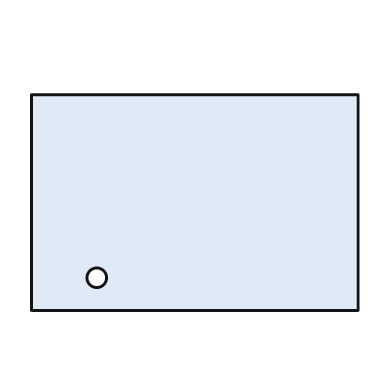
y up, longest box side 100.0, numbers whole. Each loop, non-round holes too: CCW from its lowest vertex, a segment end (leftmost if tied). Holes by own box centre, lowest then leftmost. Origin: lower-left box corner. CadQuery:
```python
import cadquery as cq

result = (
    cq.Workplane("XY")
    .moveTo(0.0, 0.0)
    .lineTo(100.0, 0.0)
    .lineTo(100.0, 66.0)
    .lineTo(0.0, 66.0)
    .close()
    .moveTo(20.0, 10.0)
    .circle(3.0)
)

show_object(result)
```